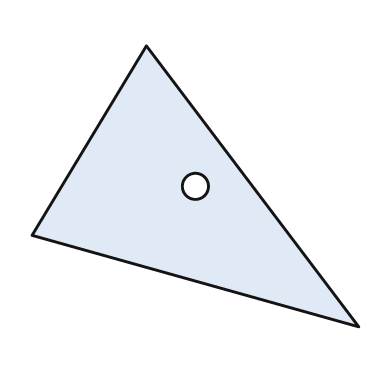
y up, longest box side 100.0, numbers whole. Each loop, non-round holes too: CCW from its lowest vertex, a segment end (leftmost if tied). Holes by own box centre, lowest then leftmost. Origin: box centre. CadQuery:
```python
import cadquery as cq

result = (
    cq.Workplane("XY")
    .moveTo(50.0, -43.0)
    .lineTo(-15.0, 43.0)
    .lineTo(-50.0, -15.0)
    .close()
    .moveTo(0.0, 0.0)
    .circle(4.0)
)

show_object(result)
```